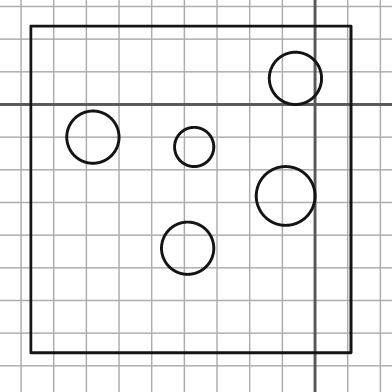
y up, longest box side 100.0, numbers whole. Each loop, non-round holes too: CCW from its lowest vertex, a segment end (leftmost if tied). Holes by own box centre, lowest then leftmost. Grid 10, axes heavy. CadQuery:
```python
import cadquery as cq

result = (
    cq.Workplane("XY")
    .moveTo(-87.0, -76.0)
    .lineTo(11.0, -76.0)
    .lineTo(11.0, 24.0)
    .lineTo(-87.0, 24.0)
    .close()
    .moveTo(-39.0, -44.0)
    .circle(8.0)
    .moveTo(-9.0, -28.0)
    .circle(9.0)
    .moveTo(-37.0, -13.0)
    .circle(6.0)
    .moveTo(-68.0, -10.0)
    .circle(8.0)
    .moveTo(-6.0, 8.0)
    .circle(8.0)
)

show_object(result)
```